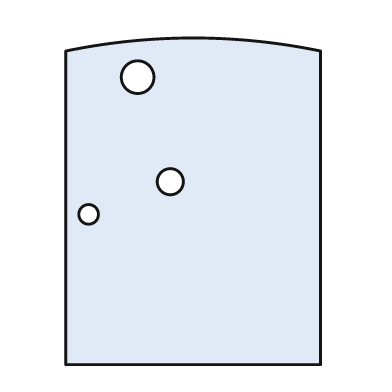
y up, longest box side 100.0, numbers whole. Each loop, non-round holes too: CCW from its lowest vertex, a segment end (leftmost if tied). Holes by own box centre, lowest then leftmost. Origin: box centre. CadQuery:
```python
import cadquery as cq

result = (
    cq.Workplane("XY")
    .moveTo(-39.0, -50.0)
    .lineTo(39.0, -50.0)
    .lineTo(39.0, 46.0)
    .threePointArc((0.0, 50.0), (-39.0, 46.0))
    .close()
    .moveTo(-32.0, -4.0)
    .circle(3.0)
    .moveTo(-7.0, 6.0)
    .circle(4.0)
    .moveTo(-17.0, 38.0)
    .circle(5.0)
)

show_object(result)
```